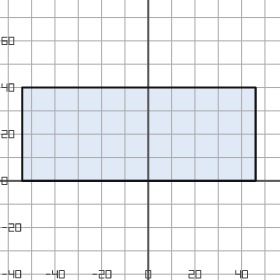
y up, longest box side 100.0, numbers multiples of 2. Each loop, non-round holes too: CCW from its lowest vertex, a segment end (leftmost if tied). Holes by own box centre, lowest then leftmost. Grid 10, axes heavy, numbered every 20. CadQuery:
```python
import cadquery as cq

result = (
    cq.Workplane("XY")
    .moveTo(-54.0, 0.0)
    .lineTo(46.0, 0.0)
    .lineTo(46.0, 40.0)
    .lineTo(-54.0, 40.0)
    .close()
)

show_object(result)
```